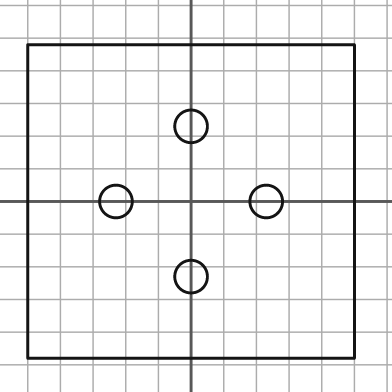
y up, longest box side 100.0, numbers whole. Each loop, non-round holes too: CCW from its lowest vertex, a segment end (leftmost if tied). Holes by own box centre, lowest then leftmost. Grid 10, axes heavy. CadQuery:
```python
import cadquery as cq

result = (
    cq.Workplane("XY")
    .moveTo(-50.0, -48.0)
    .lineTo(50.0, -48.0)
    .lineTo(50.0, 48.0)
    .lineTo(-50.0, 48.0)
    .close()
    .moveTo(0.0, -23.0)
    .circle(5.0)
    .moveTo(-23.0, 0.0)
    .circle(5.0)
    .moveTo(23.0, 0.0)
    .circle(5.0)
    .moveTo(0.0, 23.0)
    .circle(5.0)
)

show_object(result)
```